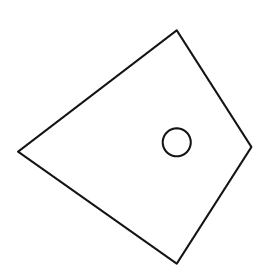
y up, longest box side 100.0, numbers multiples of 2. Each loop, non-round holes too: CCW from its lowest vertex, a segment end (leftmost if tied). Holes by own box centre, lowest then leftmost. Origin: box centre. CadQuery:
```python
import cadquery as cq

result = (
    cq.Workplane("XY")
    .moveTo(18.0, -50.0)
    .lineTo(50.0, 0.0)
    .lineTo(18.0, 50.0)
    .lineTo(-50.0, -2.0)
    .close()
    .moveTo(18.0, 2.0)
    .circle(6.0)
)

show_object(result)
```